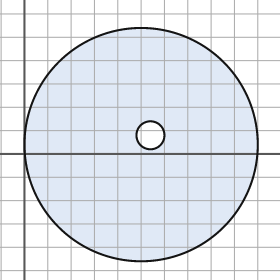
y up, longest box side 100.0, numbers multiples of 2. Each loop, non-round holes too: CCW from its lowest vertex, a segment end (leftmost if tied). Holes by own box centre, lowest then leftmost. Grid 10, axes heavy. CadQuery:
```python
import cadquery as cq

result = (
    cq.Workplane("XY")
    .moveTo(50.0, 4.0)
    .circle(50.0)
    .moveTo(54.0, 8.0)
    .circle(6.0)
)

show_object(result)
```